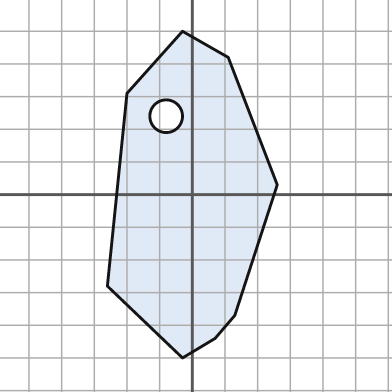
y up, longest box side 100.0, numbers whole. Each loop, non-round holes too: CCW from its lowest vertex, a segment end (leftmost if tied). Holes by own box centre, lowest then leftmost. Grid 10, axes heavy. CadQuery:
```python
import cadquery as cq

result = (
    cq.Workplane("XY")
    .moveTo(-3.0, -50.0)
    .lineTo(7.0, -44.0)
    .lineTo(13.0, -37.0)
    .lineTo(26.0, 3.0)
    .lineTo(11.0, 42.0)
    .lineTo(-3.0, 50.0)
    .lineTo(-20.0, 31.0)
    .lineTo(-26.0, -28.0)
    .close()
    .moveTo(-8.0, 24.0)
    .circle(5.0)
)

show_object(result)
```